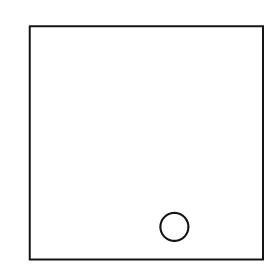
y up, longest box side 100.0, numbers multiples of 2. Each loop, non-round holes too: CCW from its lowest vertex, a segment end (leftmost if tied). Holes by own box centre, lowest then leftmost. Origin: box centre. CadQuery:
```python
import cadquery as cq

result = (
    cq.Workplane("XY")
    .moveTo(-50.0, -50.0)
    .lineTo(50.0, -50.0)
    .lineTo(50.0, 50.0)
    .lineTo(-50.0, 50.0)
    .close()
    .moveTo(12.0, -36.0)
    .circle(6.0)
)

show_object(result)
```